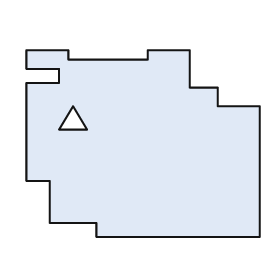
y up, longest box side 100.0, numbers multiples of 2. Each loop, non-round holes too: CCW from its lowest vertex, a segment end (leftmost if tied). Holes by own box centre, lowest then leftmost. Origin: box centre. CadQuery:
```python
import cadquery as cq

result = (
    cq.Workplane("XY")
    .moveTo(-20.0, -40.0)
    .lineTo(50.0, -40.0)
    .lineTo(50.0, 16.0)
    .lineTo(32.0, 16.0)
    .lineTo(32.0, 24.0)
    .lineTo(20.0, 24.0)
    .lineTo(20.0, 40.0)
    .lineTo(2.0, 40.0)
    .lineTo(2.0, 36.0)
    .lineTo(-32.0, 36.0)
    .lineTo(-32.0, 40.0)
    .lineTo(-50.0, 40.0)
    .lineTo(-50.0, 32.0)
    .lineTo(-36.0, 32.0)
    .lineTo(-36.0, 26.0)
    .lineTo(-50.0, 26.0)
    .lineTo(-50.0, -16.0)
    .lineTo(-40.0, -16.0)
    .lineTo(-40.0, -34.0)
    .lineTo(-20.0, -34.0)
    .close()
    .moveTo(-36.0, 6.0)
    .lineTo(-24.0, 6.0)
    .lineTo(-30.0, 16.0)
    .close()
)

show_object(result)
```